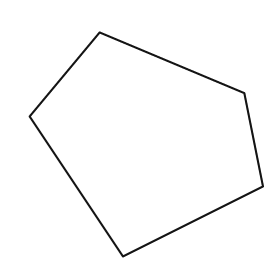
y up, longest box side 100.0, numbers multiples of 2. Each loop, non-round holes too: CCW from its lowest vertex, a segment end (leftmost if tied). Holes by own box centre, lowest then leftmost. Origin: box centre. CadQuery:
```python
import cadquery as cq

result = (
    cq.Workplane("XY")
    .moveTo(-10.0, -48.0)
    .lineTo(50.0, -18.0)
    .lineTo(42.0, 22.0)
    .lineTo(-20.0, 48.0)
    .lineTo(-50.0, 12.0)
    .close()
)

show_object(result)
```